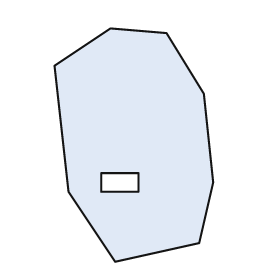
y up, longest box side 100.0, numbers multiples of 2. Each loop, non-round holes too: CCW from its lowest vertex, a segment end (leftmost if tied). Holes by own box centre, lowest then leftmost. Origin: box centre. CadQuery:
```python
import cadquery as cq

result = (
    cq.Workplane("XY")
    .moveTo(-8.0, -50.0)
    .lineTo(28.0, -42.0)
    .lineTo(34.0, -16.0)
    .lineTo(30.0, 22.0)
    .lineTo(14.0, 48.0)
    .lineTo(-10.0, 50.0)
    .lineTo(-34.0, 34.0)
    .lineTo(-28.0, -20.0)
    .close()
    .moveTo(-14.0, -20.0)
    .lineTo(2.0, -20.0)
    .lineTo(2.0, -12.0)
    .lineTo(-14.0, -12.0)
    .close()
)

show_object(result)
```